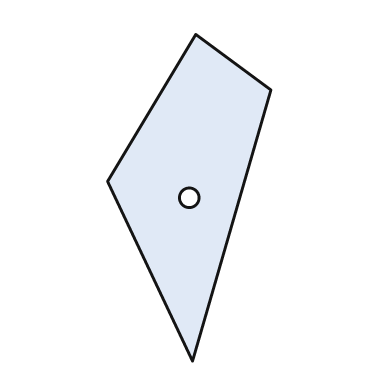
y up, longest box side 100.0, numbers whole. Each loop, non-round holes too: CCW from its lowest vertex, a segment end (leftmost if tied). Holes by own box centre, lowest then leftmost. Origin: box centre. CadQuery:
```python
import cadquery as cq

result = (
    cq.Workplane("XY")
    .moveTo(1.0, -50.0)
    .lineTo(25.0, 33.0)
    .lineTo(2.0, 50.0)
    .lineTo(-25.0, 5.0)
    .close()
    .moveTo(0.0, 0.0)
    .circle(3.0)
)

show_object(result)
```